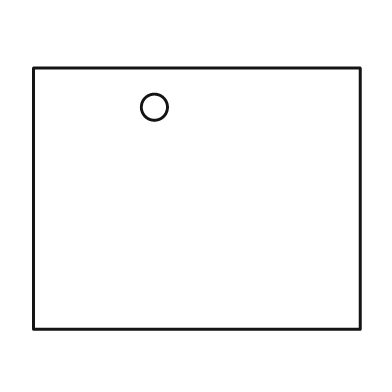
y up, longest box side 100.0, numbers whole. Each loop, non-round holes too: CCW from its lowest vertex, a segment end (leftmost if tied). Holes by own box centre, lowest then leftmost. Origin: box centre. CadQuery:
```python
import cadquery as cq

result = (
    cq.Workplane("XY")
    .moveTo(-50.0, -40.0)
    .lineTo(50.0, -40.0)
    .lineTo(50.0, 40.0)
    .lineTo(-50.0, 40.0)
    .close()
    .moveTo(-13.0, 28.0)
    .circle(4.0)
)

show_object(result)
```